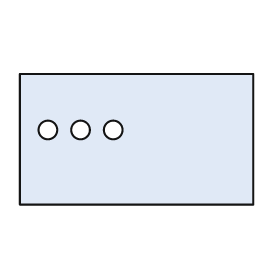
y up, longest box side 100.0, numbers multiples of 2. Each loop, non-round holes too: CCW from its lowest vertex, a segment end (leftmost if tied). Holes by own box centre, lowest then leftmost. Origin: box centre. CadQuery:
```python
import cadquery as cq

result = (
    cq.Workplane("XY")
    .moveTo(-50.0, -28.0)
    .lineTo(50.0, -28.0)
    .lineTo(50.0, 28.0)
    .lineTo(-50.0, 28.0)
    .close()
    .moveTo(-38.0, 4.0)
    .circle(4.0)
    .moveTo(-24.0, 4.0)
    .circle(4.0)
    .moveTo(-10.0, 4.0)
    .circle(4.0)
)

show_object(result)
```